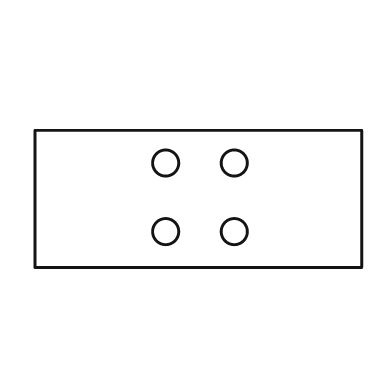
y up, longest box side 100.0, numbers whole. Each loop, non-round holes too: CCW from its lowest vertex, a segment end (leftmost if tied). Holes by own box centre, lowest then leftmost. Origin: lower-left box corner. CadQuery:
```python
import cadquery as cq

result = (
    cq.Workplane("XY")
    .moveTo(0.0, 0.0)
    .lineTo(100.0, 0.0)
    .lineTo(100.0, 42.0)
    .lineTo(0.0, 42.0)
    .close()
    .moveTo(40.0, 11.0)
    .circle(4.0)
    .moveTo(61.0, 11.0)
    .circle(4.0)
    .moveTo(40.0, 32.0)
    .circle(4.0)
    .moveTo(61.0, 32.0)
    .circle(4.0)
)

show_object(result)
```